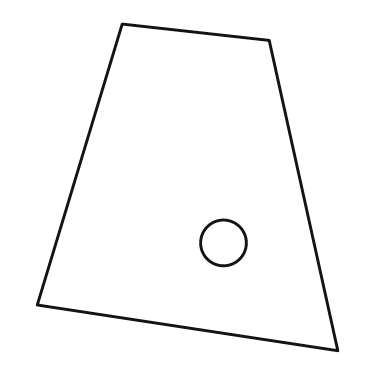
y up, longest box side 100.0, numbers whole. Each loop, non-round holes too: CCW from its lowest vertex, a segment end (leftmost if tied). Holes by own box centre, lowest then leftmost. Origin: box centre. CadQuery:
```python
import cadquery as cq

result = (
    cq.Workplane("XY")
    .moveTo(46.0, -50.0)
    .lineTo(25.0, 45.0)
    .lineTo(-20.0, 50.0)
    .lineTo(-46.0, -36.0)
    .close()
    .moveTo(11.0, -17.0)
    .circle(7.0)
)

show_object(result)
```